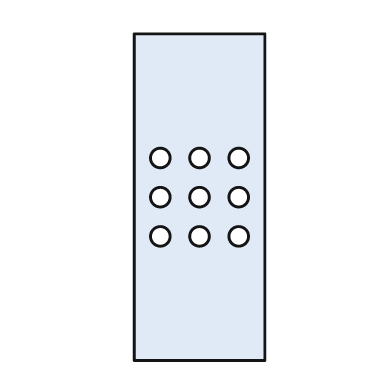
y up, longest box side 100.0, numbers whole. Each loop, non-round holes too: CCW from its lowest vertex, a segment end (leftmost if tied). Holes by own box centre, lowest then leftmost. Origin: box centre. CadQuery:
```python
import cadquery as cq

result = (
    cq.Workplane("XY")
    .moveTo(-20.0, -50.0)
    .lineTo(20.0, -50.0)
    .lineTo(20.0, 50.0)
    .lineTo(-20.0, 50.0)
    .close()
    .moveTo(-12.0, -12.0)
    .circle(3.0)
    .moveTo(0.0, -12.0)
    .circle(3.0)
    .moveTo(12.0, -12.0)
    .circle(3.0)
    .moveTo(-12.0, 0.0)
    .circle(3.0)
    .moveTo(0.0, 0.0)
    .circle(3.0)
    .moveTo(12.0, 0.0)
    .circle(3.0)
    .moveTo(-12.0, 12.0)
    .circle(3.0)
    .moveTo(0.0, 12.0)
    .circle(3.0)
    .moveTo(12.0, 12.0)
    .circle(3.0)
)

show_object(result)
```